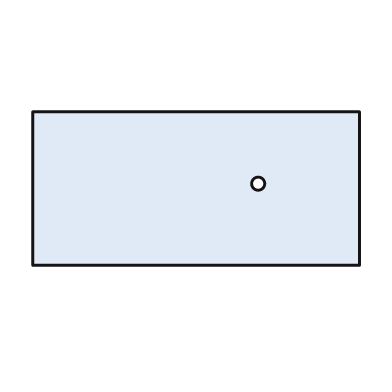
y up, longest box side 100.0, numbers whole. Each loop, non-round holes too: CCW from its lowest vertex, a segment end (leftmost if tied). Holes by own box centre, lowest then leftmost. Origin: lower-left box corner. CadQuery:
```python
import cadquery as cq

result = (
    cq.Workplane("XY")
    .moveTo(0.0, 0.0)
    .lineTo(100.0, 0.0)
    .lineTo(100.0, 47.0)
    .lineTo(0.0, 47.0)
    .close()
    .moveTo(69.0, 25.0)
    .circle(2.0)
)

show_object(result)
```